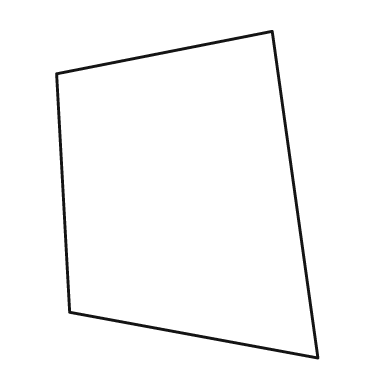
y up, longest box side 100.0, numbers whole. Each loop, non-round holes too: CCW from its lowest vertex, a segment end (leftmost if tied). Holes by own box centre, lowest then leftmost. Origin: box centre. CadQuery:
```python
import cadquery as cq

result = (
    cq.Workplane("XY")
    .moveTo(40.0, -50.0)
    .lineTo(26.0, 50.0)
    .lineTo(-40.0, 37.0)
    .lineTo(-36.0, -36.0)
    .close()
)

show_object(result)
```